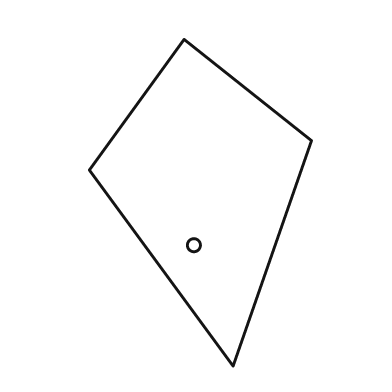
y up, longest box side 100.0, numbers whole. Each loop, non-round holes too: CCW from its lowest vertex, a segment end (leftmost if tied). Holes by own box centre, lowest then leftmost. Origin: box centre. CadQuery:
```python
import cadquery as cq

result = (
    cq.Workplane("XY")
    .moveTo(10.0, -50.0)
    .lineTo(34.0, 19.0)
    .lineTo(-5.0, 50.0)
    .lineTo(-34.0, 10.0)
    .close()
    .moveTo(-2.0, -13.0)
    .circle(2.0)
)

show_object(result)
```